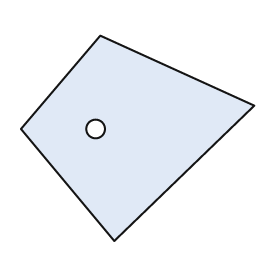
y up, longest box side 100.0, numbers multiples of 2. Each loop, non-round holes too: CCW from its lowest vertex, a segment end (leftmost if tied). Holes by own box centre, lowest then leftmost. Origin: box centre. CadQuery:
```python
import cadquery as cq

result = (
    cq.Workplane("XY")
    .moveTo(-10.0, -44.0)
    .lineTo(50.0, 14.0)
    .lineTo(-16.0, 44.0)
    .lineTo(-50.0, 4.0)
    .close()
    .moveTo(-18.0, 4.0)
    .circle(4.0)
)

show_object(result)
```